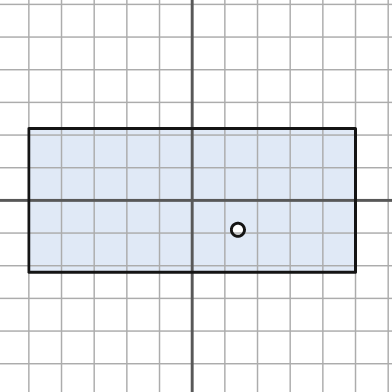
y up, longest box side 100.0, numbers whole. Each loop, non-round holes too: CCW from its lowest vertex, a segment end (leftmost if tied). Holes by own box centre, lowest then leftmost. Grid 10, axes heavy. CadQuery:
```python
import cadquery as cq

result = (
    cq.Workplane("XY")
    .moveTo(-50.0, -22.0)
    .lineTo(50.0, -22.0)
    .lineTo(50.0, 22.0)
    .lineTo(-50.0, 22.0)
    .close()
    .moveTo(14.0, -9.0)
    .circle(2.0)
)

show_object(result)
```